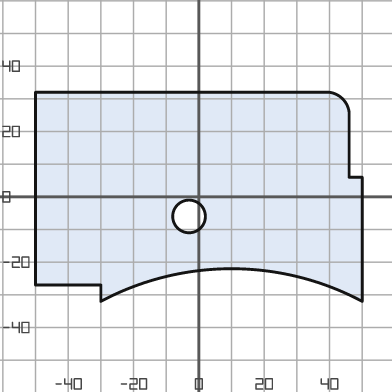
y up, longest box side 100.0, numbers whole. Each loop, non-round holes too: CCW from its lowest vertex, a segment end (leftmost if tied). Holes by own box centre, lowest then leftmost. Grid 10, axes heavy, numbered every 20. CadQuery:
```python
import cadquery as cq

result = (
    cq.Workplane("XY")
    .moveTo(-30.0, -32.0)
    .threePointArc((10.0, -22.0), (50.0, -32.0))
    .lineTo(50.0, 6.0)
    .lineTo(46.0, 6.0)
    .lineTo(46.0, 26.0)
    .threePointArc((44.0, 30.0), (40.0, 32.0))
    .lineTo(-50.0, 32.0)
    .lineTo(-50.0, -27.0)
    .lineTo(-30.0, -27.0)
    .close()
    .moveTo(-3.0, -6.0)
    .circle(5.0)
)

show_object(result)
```